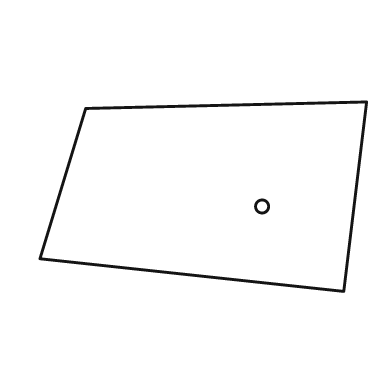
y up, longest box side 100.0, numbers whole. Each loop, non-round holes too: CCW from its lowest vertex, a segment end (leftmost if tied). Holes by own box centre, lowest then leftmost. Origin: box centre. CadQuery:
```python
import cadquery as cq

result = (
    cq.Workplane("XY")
    .moveTo(43.0, -29.0)
    .lineTo(50.0, 29.0)
    .lineTo(-36.0, 27.0)
    .lineTo(-50.0, -19.0)
    .close()
    .moveTo(18.0, -3.0)
    .circle(2.0)
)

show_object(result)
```